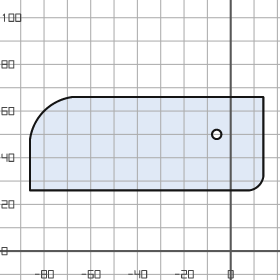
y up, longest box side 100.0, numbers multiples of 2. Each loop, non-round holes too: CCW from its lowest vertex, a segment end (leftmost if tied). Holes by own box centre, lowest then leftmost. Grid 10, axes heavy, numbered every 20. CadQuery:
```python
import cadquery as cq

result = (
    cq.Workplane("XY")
    .moveTo(-86.0, 26.0)
    .lineTo(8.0, 26.0)
    .threePointArc((12.0, 28.0), (14.0, 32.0))
    .lineTo(14.0, 66.0)
    .lineTo(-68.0, 66.0)
    .threePointArc((-80.0, 60.0), (-86.0, 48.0))
    .close()
    .moveTo(-6.0, 50.0)
    .circle(2.0)
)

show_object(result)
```